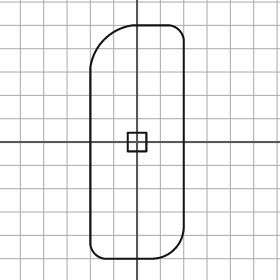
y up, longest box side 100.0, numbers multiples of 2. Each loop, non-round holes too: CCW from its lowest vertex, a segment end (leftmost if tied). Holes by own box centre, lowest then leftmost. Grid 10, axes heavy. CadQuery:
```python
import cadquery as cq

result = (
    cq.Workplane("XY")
    .moveTo(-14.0, -50.0)
    .lineTo(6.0, -50.0)
    .threePointArc((16.0, -46.0), (20.0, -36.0))
    .lineTo(20.0, 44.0)
    .threePointArc((18.0, 48.0), (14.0, 50.0))
    .lineTo(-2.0, 50.0)
    .threePointArc((-14.0, 44.0), (-20.0, 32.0))
    .lineTo(-20.0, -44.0)
    .threePointArc((-18.0, -48.0), (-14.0, -50.0))
    .close()
    .moveTo(-4.0, -4.0)
    .lineTo(4.0, -4.0)
    .lineTo(4.0, 4.0)
    .lineTo(-4.0, 4.0)
    .close()
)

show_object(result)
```